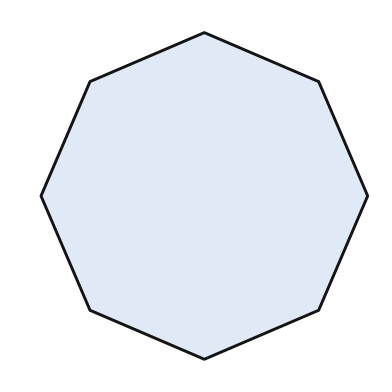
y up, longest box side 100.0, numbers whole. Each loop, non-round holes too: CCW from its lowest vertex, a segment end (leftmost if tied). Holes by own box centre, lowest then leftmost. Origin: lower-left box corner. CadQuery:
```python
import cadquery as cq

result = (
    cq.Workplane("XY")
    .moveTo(50.0, 0.0)
    .lineTo(85.0, 15.0)
    .lineTo(100.0, 50.0)
    .lineTo(85.0, 85.0)
    .lineTo(50.0, 100.0)
    .lineTo(15.0, 85.0)
    .lineTo(0.0, 50.0)
    .lineTo(15.0, 15.0)
    .close()
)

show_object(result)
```